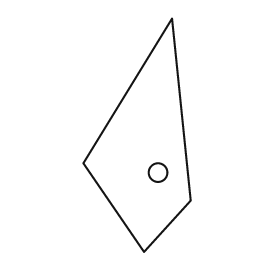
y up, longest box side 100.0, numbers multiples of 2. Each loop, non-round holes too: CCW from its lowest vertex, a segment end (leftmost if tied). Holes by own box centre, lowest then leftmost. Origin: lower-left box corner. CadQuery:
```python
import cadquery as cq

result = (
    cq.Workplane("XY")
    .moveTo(26.0, 0.0)
    .lineTo(46.0, 22.0)
    .lineTo(38.0, 100.0)
    .lineTo(0.0, 38.0)
    .close()
    .moveTo(32.0, 34.0)
    .circle(4.0)
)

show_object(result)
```